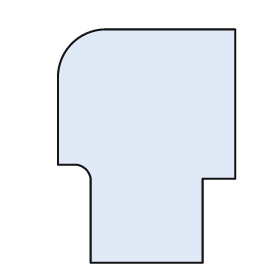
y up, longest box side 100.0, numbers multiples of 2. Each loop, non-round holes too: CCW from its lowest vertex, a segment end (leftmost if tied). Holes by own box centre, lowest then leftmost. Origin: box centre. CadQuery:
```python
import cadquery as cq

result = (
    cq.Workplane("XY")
    .moveTo(-24.0, -50.0)
    .lineTo(24.0, -50.0)
    .lineTo(24.0, -14.0)
    .lineTo(38.0, -14.0)
    .lineTo(38.0, 50.0)
    .lineTo(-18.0, 50.0)
    .threePointArc((-32.0, 44.0), (-38.0, 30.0))
    .lineTo(-38.0, -8.0)
    .lineTo(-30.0, -8.0)
    .threePointArc((-26.0, -10.0), (-24.0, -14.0))
    .close()
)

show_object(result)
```